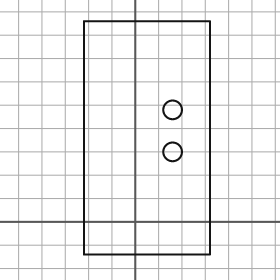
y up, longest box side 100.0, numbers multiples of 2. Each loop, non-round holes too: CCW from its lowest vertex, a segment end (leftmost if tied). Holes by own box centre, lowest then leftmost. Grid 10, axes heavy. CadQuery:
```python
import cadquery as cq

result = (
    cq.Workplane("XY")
    .moveTo(-22.0, -14.0)
    .lineTo(32.0, -14.0)
    .lineTo(32.0, 86.0)
    .lineTo(-22.0, 86.0)
    .close()
    .moveTo(16.0, 30.0)
    .circle(4.0)
    .moveTo(16.0, 48.0)
    .circle(4.0)
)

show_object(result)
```